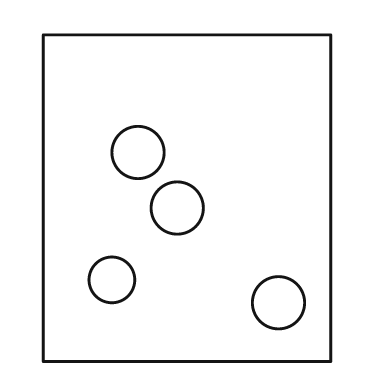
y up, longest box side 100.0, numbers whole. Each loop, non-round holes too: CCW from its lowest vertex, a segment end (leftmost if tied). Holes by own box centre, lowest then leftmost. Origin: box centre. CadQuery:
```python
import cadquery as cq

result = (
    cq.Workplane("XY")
    .moveTo(-44.0, -50.0)
    .lineTo(44.0, -50.0)
    .lineTo(44.0, 50.0)
    .lineTo(-44.0, 50.0)
    .close()
    .moveTo(28.0, -32.0)
    .circle(8.0)
    .moveTo(-23.0, -25.0)
    .circle(7.0)
    .moveTo(-3.0, -3.0)
    .circle(8.0)
    .moveTo(-15.0, 14.0)
    .circle(8.0)
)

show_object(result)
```